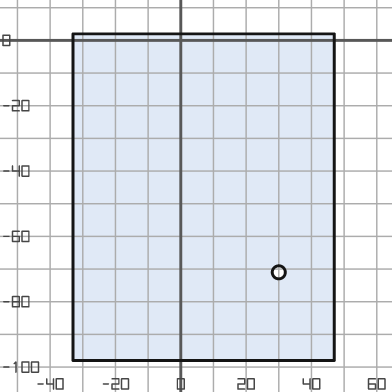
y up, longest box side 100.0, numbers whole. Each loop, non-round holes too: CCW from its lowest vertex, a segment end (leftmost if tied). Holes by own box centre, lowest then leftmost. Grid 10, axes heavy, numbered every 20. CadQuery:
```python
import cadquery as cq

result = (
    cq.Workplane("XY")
    .moveTo(-33.0, -98.0)
    .lineTo(47.0, -98.0)
    .lineTo(47.0, 2.0)
    .lineTo(-33.0, 2.0)
    .close()
    .moveTo(30.0, -71.0)
    .circle(2.0)
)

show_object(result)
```